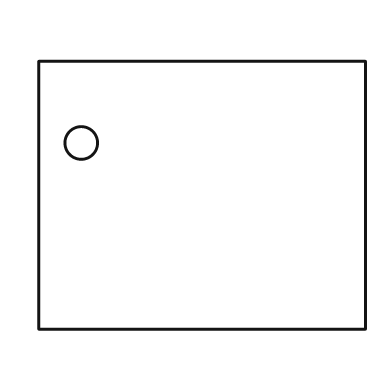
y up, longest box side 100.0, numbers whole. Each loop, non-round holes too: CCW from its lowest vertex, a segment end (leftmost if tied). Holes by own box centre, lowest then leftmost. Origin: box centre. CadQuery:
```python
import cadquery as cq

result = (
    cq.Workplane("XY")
    .moveTo(-50.0, -41.0)
    .lineTo(50.0, -41.0)
    .lineTo(50.0, 41.0)
    .lineTo(-50.0, 41.0)
    .close()
    .moveTo(-37.0, 16.0)
    .circle(5.0)
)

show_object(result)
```